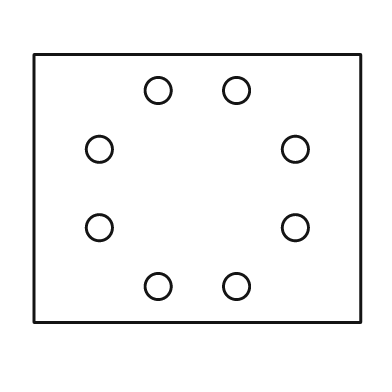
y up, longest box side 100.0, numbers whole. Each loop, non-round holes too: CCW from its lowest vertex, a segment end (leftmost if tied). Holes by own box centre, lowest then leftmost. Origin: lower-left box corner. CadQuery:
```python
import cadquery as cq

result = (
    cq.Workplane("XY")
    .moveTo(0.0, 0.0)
    .lineTo(100.0, 0.0)
    .lineTo(100.0, 82.0)
    .lineTo(0.0, 82.0)
    .close()
    .moveTo(38.0, 11.0)
    .circle(4.0)
    .moveTo(62.0, 11.0)
    .circle(4.0)
    .moveTo(20.0, 29.0)
    .circle(4.0)
    .moveTo(80.0, 29.0)
    .circle(4.0)
    .moveTo(20.0, 53.0)
    .circle(4.0)
    .moveTo(80.0, 53.0)
    .circle(4.0)
    .moveTo(38.0, 71.0)
    .circle(4.0)
    .moveTo(62.0, 71.0)
    .circle(4.0)
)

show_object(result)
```